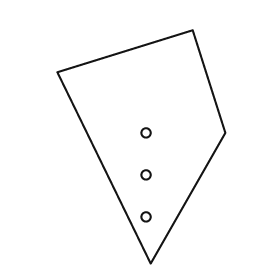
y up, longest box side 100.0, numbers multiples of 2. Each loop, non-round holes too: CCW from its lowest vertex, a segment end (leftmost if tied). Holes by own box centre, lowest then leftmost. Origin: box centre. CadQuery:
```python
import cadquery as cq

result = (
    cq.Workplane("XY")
    .moveTo(4.0, -50.0)
    .lineTo(36.0, 6.0)
    .lineTo(22.0, 50.0)
    .lineTo(-36.0, 32.0)
    .close()
    .moveTo(2.0, -30.0)
    .circle(2.0)
    .moveTo(2.0, -12.0)
    .circle(2.0)
    .moveTo(2.0, 6.0)
    .circle(2.0)
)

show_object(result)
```